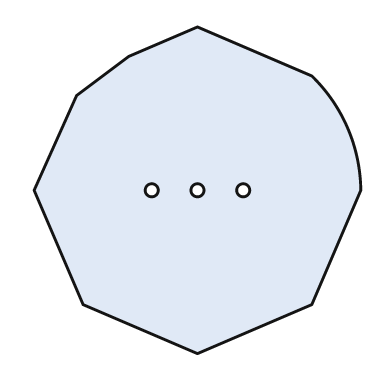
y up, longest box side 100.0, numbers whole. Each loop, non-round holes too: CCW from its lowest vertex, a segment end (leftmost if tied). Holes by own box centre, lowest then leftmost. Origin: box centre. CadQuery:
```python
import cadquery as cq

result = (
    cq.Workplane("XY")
    .moveTo(0.0, -50.0)
    .lineTo(35.0, -35.0)
    .lineTo(50.0, 0.0)
    .threePointArc((46.0, 19.0), (35.0, 35.0))
    .lineTo(0.0, 50.0)
    .lineTo(-21.0, 41.0)
    .lineTo(-37.0, 29.0)
    .lineTo(-50.0, 0.0)
    .lineTo(-35.0, -35.0)
    .close()
    .moveTo(-14.0, 0.0)
    .circle(2.0)
    .moveTo(0.0, 0.0)
    .circle(2.0)
    .moveTo(14.0, 0.0)
    .circle(2.0)
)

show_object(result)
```